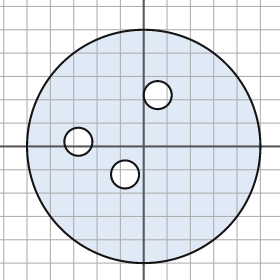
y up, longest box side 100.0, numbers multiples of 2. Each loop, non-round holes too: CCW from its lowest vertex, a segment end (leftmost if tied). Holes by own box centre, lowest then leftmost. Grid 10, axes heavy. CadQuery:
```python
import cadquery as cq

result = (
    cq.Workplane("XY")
    .moveTo(0.0, 0.0)
    .circle(50.0)
    .moveTo(-8.0, -12.0)
    .circle(6.0)
    .moveTo(-28.0, 2.0)
    .circle(6.0)
    .moveTo(6.0, 22.0)
    .circle(6.0)
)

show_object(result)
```